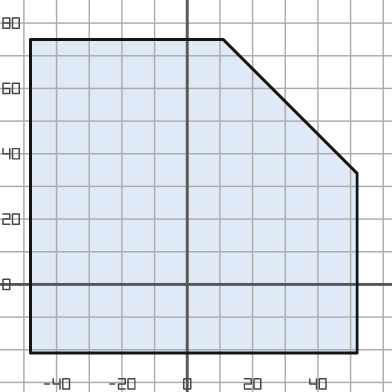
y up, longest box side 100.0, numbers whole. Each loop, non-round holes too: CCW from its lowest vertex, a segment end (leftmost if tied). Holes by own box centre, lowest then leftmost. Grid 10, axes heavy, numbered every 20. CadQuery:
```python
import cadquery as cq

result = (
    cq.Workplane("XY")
    .moveTo(-48.0, -21.0)
    .lineTo(52.0, -21.0)
    .lineTo(52.0, 34.0)
    .lineTo(11.0, 75.0)
    .lineTo(-48.0, 75.0)
    .close()
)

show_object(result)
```